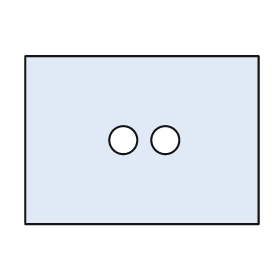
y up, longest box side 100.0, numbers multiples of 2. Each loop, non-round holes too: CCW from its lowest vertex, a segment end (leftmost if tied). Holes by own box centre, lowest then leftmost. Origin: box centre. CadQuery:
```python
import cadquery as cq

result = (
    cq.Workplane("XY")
    .moveTo(-50.0, -36.0)
    .lineTo(50.0, -36.0)
    .lineTo(50.0, 36.0)
    .lineTo(-50.0, 36.0)
    .close()
    .moveTo(-8.0, 0.0)
    .circle(6.0)
    .moveTo(10.0, 0.0)
    .circle(6.0)
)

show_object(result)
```